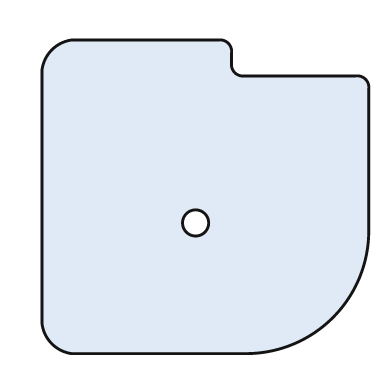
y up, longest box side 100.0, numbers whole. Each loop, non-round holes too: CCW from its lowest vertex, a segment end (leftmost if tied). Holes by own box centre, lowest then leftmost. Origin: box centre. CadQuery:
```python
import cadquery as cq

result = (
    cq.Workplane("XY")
    .moveTo(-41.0, -48.0)
    .lineTo(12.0, -48.0)
    .threePointArc((39.0, -37.0), (50.0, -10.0))
    .lineTo(50.0, 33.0)
    .threePointArc((49.0, 36.0), (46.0, 37.0))
    .lineTo(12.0, 37.0)
    .threePointArc((9.0, 38.0), (8.0, 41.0))
    .lineTo(8.0, 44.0)
    .threePointArc((7.0, 47.0), (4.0, 48.0))
    .lineTo(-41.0, 48.0)
    .threePointArc((-47.0, 45.0), (-50.0, 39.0))
    .lineTo(-50.0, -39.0)
    .threePointArc((-47.0, -45.0), (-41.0, -48.0))
    .close()
    .moveTo(-3.0, -8.0)
    .circle(4.0)
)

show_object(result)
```